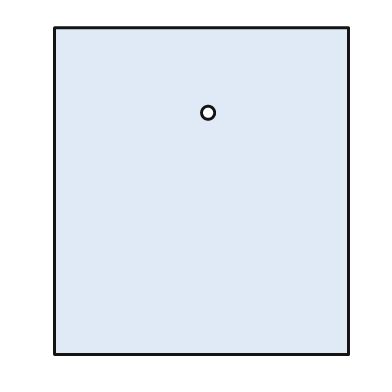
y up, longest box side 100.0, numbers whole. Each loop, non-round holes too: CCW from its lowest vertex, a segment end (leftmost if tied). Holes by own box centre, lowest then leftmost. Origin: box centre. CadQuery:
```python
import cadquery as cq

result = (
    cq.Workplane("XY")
    .moveTo(-45.0, -50.0)
    .lineTo(45.0, -50.0)
    .lineTo(45.0, 50.0)
    .lineTo(-45.0, 50.0)
    .close()
    .moveTo(2.0, 24.0)
    .circle(2.0)
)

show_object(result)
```